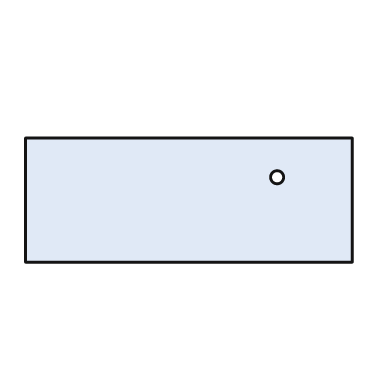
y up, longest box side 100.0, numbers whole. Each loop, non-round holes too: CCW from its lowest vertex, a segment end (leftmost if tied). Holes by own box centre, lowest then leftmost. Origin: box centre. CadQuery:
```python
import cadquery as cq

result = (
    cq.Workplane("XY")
    .moveTo(-50.0, -19.0)
    .lineTo(50.0, -19.0)
    .lineTo(50.0, 19.0)
    .lineTo(-50.0, 19.0)
    .close()
    .moveTo(27.0, 7.0)
    .circle(2.0)
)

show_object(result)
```